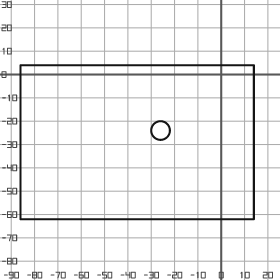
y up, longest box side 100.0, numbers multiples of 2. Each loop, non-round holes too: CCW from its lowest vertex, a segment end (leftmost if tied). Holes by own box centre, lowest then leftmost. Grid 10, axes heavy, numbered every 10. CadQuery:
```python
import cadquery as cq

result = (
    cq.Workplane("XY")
    .moveTo(-86.0, -62.0)
    .lineTo(14.0, -62.0)
    .lineTo(14.0, 4.0)
    .lineTo(-86.0, 4.0)
    .close()
    .moveTo(-26.0, -24.0)
    .circle(4.0)
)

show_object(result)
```